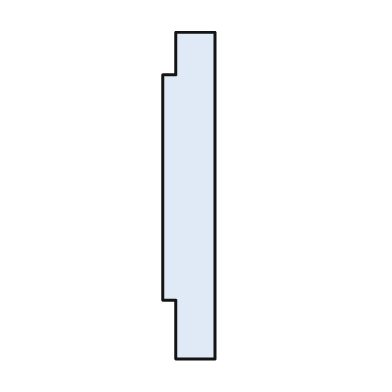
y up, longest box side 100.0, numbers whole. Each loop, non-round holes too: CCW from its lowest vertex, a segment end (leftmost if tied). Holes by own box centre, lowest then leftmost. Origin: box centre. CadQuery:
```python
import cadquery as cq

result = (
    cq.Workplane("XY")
    .moveTo(-4.0, -50.0)
    .lineTo(8.0, -50.0)
    .lineTo(8.0, 50.0)
    .lineTo(-4.0, 50.0)
    .lineTo(-4.0, 37.0)
    .lineTo(-8.0, 37.0)
    .lineTo(-8.0, -32.0)
    .lineTo(-4.0, -32.0)
    .close()
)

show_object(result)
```